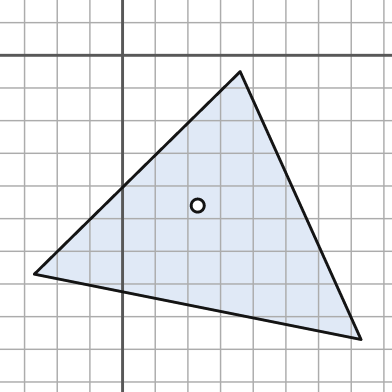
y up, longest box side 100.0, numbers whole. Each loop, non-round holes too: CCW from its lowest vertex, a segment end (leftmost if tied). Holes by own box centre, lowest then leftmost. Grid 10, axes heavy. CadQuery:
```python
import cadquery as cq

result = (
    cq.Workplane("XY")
    .moveTo(73.0, -87.0)
    .lineTo(36.0, -5.0)
    .lineTo(-27.0, -67.0)
    .close()
    .moveTo(23.0, -46.0)
    .circle(2.0)
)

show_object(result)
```